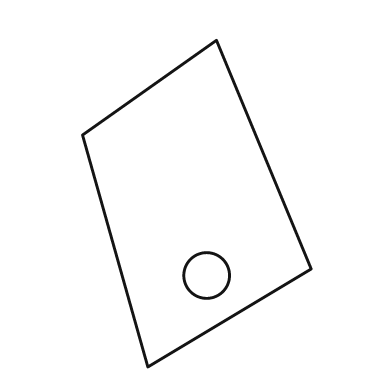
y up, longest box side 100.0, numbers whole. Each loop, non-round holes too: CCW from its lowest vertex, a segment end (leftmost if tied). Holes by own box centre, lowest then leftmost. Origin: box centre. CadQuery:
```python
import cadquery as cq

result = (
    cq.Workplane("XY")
    .moveTo(-15.0, -50.0)
    .lineTo(35.0, -20.0)
    .lineTo(6.0, 50.0)
    .lineTo(-35.0, 21.0)
    .close()
    .moveTo(3.0, -22.0)
    .circle(7.0)
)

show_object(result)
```